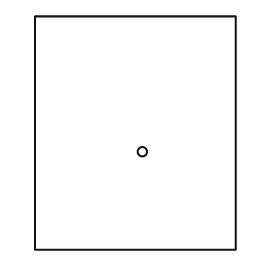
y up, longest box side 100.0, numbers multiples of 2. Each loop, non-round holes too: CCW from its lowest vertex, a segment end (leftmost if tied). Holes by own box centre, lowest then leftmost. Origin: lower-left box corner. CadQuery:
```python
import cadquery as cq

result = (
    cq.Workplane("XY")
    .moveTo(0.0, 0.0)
    .lineTo(86.0, 0.0)
    .lineTo(86.0, 100.0)
    .lineTo(0.0, 100.0)
    .close()
    .moveTo(46.0, 42.0)
    .circle(2.0)
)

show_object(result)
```